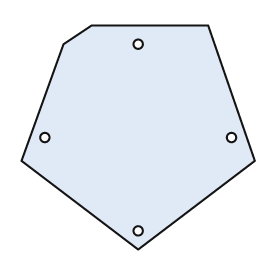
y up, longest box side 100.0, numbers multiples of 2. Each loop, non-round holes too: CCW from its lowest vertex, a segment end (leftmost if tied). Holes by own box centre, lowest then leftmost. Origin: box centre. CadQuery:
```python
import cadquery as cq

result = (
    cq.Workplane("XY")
    .moveTo(0.0, -48.0)
    .lineTo(50.0, -10.0)
    .lineTo(30.0, 48.0)
    .lineTo(-20.0, 48.0)
    .lineTo(-32.0, 40.0)
    .lineTo(-50.0, -10.0)
    .close()
    .moveTo(0.0, -40.0)
    .circle(2.0)
    .moveTo(-40.0, 0.0)
    .circle(2.0)
    .moveTo(40.0, 0.0)
    .circle(2.0)
    .moveTo(0.0, 40.0)
    .circle(2.0)
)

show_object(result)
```